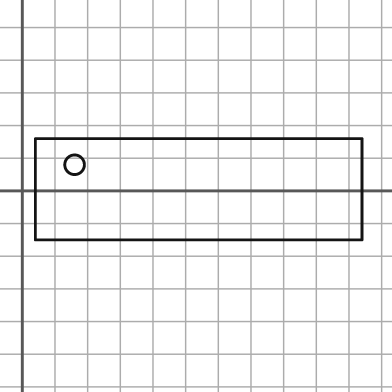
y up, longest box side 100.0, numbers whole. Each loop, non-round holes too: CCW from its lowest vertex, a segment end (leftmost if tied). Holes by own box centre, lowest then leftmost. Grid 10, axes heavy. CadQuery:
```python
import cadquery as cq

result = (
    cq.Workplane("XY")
    .moveTo(4.0, -15.0)
    .lineTo(104.0, -15.0)
    .lineTo(104.0, 16.0)
    .lineTo(4.0, 16.0)
    .close()
    .moveTo(16.0, 8.0)
    .circle(3.0)
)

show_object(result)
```